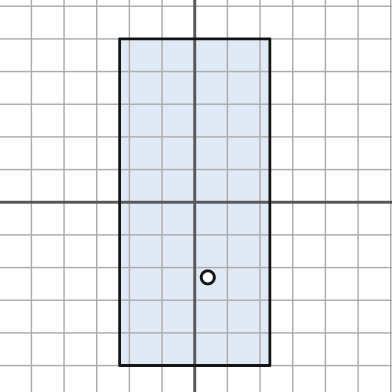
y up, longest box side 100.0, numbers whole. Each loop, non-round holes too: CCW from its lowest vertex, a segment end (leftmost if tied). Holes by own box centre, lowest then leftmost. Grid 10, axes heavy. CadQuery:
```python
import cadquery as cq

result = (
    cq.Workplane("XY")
    .moveTo(-23.0, -50.0)
    .lineTo(23.0, -50.0)
    .lineTo(23.0, 50.0)
    .lineTo(-23.0, 50.0)
    .close()
    .moveTo(4.0, -23.0)
    .circle(2.0)
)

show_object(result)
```